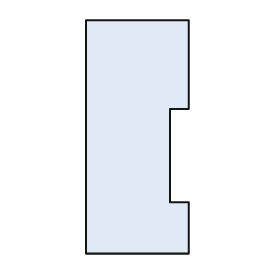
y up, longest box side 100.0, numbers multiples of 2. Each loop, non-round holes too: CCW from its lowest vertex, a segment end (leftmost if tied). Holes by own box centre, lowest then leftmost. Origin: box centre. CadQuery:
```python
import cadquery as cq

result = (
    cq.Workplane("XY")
    .moveTo(-22.0, -50.0)
    .lineTo(22.0, -50.0)
    .lineTo(22.0, -28.0)
    .lineTo(14.0, -28.0)
    .lineTo(14.0, 12.0)
    .lineTo(22.0, 12.0)
    .lineTo(22.0, 50.0)
    .lineTo(-22.0, 50.0)
    .close()
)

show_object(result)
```